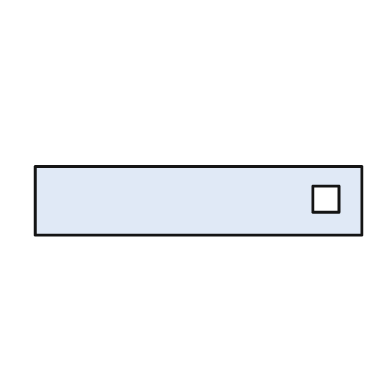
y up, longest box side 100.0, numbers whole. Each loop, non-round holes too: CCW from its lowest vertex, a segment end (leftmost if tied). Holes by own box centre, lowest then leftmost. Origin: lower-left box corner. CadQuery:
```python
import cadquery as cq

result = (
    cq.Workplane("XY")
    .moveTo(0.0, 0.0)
    .lineTo(100.0, 0.0)
    .lineTo(100.0, 21.0)
    .lineTo(0.0, 21.0)
    .close()
    .moveTo(85.0, 7.0)
    .lineTo(93.0, 7.0)
    .lineTo(93.0, 15.0)
    .lineTo(85.0, 15.0)
    .close()
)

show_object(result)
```